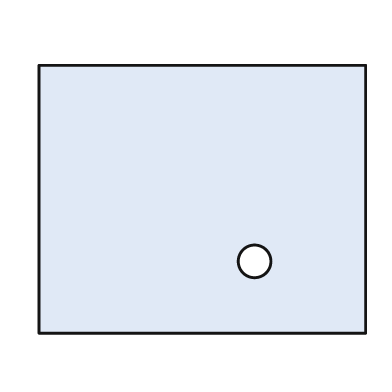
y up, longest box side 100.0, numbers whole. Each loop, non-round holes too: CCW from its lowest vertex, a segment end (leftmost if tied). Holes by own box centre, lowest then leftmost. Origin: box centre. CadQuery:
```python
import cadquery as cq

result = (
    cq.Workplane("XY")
    .moveTo(-50.0, -41.0)
    .lineTo(50.0, -41.0)
    .lineTo(50.0, 41.0)
    .lineTo(-50.0, 41.0)
    .close()
    .moveTo(16.0, -19.0)
    .circle(5.0)
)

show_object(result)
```